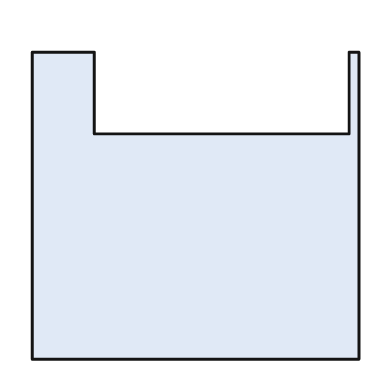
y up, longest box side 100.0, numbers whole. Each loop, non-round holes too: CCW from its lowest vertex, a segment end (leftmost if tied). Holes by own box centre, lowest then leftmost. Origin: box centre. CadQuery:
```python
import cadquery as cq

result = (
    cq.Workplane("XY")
    .moveTo(-50.0, -47.0)
    .lineTo(50.0, -47.0)
    .lineTo(50.0, 47.0)
    .lineTo(47.0, 47.0)
    .lineTo(47.0, 22.0)
    .lineTo(-31.0, 22.0)
    .lineTo(-31.0, 47.0)
    .lineTo(-50.0, 47.0)
    .close()
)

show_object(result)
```